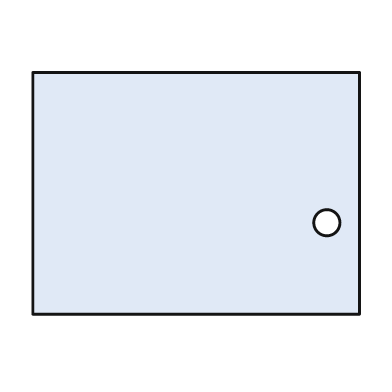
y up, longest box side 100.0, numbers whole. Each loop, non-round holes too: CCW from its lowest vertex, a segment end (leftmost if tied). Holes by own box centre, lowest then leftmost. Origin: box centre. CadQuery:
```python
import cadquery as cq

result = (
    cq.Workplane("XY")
    .moveTo(-50.0, -37.0)
    .lineTo(50.0, -37.0)
    .lineTo(50.0, 37.0)
    .lineTo(-50.0, 37.0)
    .close()
    .moveTo(40.0, -9.0)
    .circle(4.0)
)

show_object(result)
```